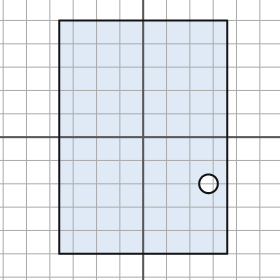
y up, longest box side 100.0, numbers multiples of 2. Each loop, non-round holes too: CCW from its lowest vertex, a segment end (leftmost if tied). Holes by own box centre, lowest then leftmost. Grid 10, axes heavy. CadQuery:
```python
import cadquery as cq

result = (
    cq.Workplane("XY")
    .moveTo(-36.0, -50.0)
    .lineTo(36.0, -50.0)
    .lineTo(36.0, 50.0)
    .lineTo(-36.0, 50.0)
    .close()
    .moveTo(28.0, -20.0)
    .circle(4.0)
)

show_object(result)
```